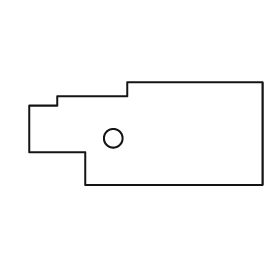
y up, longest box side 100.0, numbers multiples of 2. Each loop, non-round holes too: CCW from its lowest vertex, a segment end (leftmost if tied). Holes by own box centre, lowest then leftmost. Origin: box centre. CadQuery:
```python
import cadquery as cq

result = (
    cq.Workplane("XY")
    .moveTo(-26.0, -22.0)
    .lineTo(50.0, -22.0)
    .lineTo(50.0, 22.0)
    .lineTo(-8.0, 22.0)
    .lineTo(-8.0, 16.0)
    .lineTo(-38.0, 16.0)
    .lineTo(-38.0, 12.0)
    .lineTo(-50.0, 12.0)
    .lineTo(-50.0, -8.0)
    .lineTo(-26.0, -8.0)
    .close()
    .moveTo(-14.0, -2.0)
    .circle(4.0)
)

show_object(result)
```